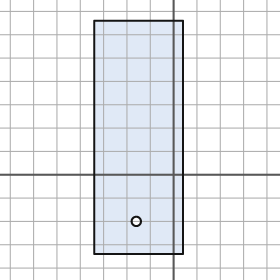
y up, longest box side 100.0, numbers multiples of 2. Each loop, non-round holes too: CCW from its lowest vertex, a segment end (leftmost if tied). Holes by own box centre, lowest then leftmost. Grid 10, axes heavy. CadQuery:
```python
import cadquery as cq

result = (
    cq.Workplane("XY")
    .moveTo(-34.0, -34.0)
    .lineTo(4.0, -34.0)
    .lineTo(4.0, 66.0)
    .lineTo(-34.0, 66.0)
    .close()
    .moveTo(-16.0, -20.0)
    .circle(2.0)
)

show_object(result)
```